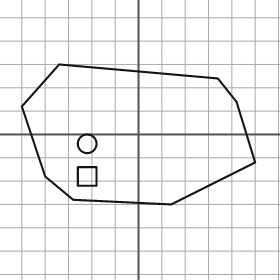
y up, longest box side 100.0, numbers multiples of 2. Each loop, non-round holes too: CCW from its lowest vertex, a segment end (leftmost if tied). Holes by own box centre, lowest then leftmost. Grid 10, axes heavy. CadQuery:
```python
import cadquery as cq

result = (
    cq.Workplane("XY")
    .moveTo(14.0, -30.0)
    .lineTo(50.0, -12.0)
    .lineTo(42.0, 14.0)
    .lineTo(34.0, 24.0)
    .lineTo(-34.0, 30.0)
    .lineTo(-50.0, 12.0)
    .lineTo(-40.0, -18.0)
    .lineTo(-28.0, -28.0)
    .close()
    .moveTo(-26.0, -22.0)
    .lineTo(-18.0, -22.0)
    .lineTo(-18.0, -14.0)
    .lineTo(-26.0, -14.0)
    .close()
    .moveTo(-22.0, -4.0)
    .circle(4.0)
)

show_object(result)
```